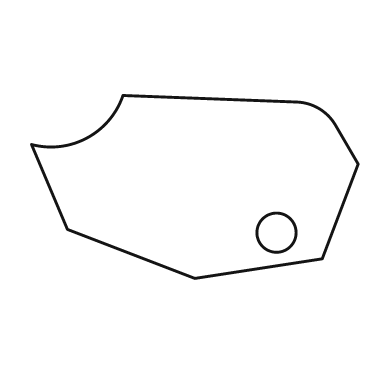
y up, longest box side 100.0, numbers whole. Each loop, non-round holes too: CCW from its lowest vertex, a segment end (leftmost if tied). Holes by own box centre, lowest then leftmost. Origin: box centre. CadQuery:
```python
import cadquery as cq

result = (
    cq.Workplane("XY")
    .moveTo(0.0, -28.0)
    .lineTo(39.0, -22.0)
    .lineTo(50.0, 7.0)
    .lineTo(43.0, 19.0)
    .threePointArc((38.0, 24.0), (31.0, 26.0))
    .lineTo(-22.0, 28.0)
    .threePointArc((-33.0, 15.0), (-50.0, 13.0))
    .lineTo(-39.0, -13.0)
    .close()
    .moveTo(25.0, -14.0)
    .circle(6.0)
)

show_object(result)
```